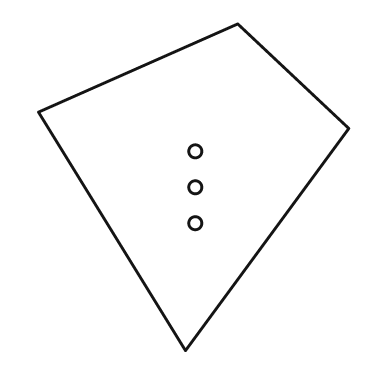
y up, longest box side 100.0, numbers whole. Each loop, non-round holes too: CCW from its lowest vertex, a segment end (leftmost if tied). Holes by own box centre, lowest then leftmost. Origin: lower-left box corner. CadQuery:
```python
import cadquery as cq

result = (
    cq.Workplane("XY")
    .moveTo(45.0, 0.0)
    .lineTo(95.0, 68.0)
    .lineTo(61.0, 100.0)
    .lineTo(0.0, 73.0)
    .close()
    .moveTo(48.0, 39.0)
    .circle(2.0)
    .moveTo(48.0, 50.0)
    .circle(2.0)
    .moveTo(48.0, 61.0)
    .circle(2.0)
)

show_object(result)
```